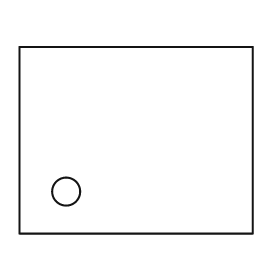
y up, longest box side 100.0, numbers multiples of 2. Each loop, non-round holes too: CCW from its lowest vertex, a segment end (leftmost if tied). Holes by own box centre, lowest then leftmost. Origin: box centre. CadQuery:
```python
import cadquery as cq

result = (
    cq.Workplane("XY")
    .moveTo(-50.0, -40.0)
    .lineTo(50.0, -40.0)
    .lineTo(50.0, 40.0)
    .lineTo(-50.0, 40.0)
    .close()
    .moveTo(-30.0, -22.0)
    .circle(6.0)
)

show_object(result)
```